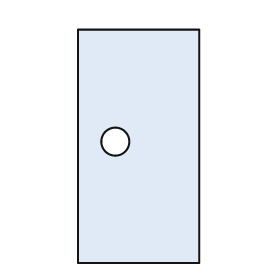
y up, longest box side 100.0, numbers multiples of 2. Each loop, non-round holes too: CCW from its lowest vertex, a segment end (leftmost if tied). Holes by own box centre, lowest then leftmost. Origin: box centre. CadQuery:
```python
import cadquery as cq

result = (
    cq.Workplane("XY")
    .moveTo(-26.0, -50.0)
    .lineTo(26.0, -50.0)
    .lineTo(26.0, 50.0)
    .lineTo(-26.0, 50.0)
    .close()
    .moveTo(-10.0, 2.0)
    .circle(6.0)
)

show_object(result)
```